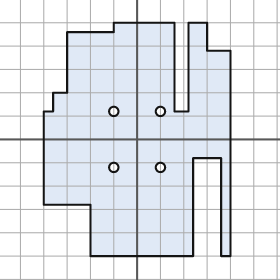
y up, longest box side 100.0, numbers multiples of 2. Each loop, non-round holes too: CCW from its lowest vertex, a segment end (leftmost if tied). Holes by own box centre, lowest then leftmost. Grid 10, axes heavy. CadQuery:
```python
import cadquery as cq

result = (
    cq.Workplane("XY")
    .moveTo(-20.0, -50.0)
    .lineTo(24.0, -50.0)
    .lineTo(24.0, -8.0)
    .lineTo(36.0, -8.0)
    .lineTo(36.0, -50.0)
    .lineTo(40.0, -50.0)
    .lineTo(40.0, 38.0)
    .lineTo(30.0, 38.0)
    .lineTo(30.0, 50.0)
    .lineTo(22.0, 50.0)
    .lineTo(22.0, 12.0)
    .lineTo(16.0, 12.0)
    .lineTo(16.0, 50.0)
    .lineTo(-10.0, 50.0)
    .lineTo(-10.0, 46.0)
    .lineTo(-30.0, 46.0)
    .lineTo(-30.0, 20.0)
    .lineTo(-36.0, 20.0)
    .lineTo(-36.0, 12.0)
    .lineTo(-40.0, 12.0)
    .lineTo(-40.0, -28.0)
    .lineTo(-20.0, -28.0)
    .close()
    .moveTo(-10.0, -12.0)
    .circle(2.0)
    .moveTo(10.0, -12.0)
    .circle(2.0)
    .moveTo(-10.0, 12.0)
    .circle(2.0)
    .moveTo(10.0, 12.0)
    .circle(2.0)
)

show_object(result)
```